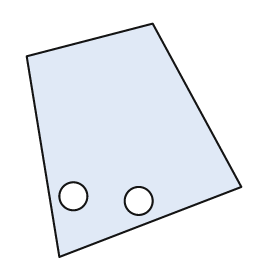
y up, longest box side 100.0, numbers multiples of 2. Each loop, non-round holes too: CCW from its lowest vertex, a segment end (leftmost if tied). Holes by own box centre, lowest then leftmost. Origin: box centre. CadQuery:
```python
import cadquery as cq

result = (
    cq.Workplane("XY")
    .moveTo(-32.0, -50.0)
    .lineTo(46.0, -20.0)
    .lineTo(8.0, 50.0)
    .lineTo(-46.0, 36.0)
    .close()
    .moveTo(2.0, -26.0)
    .circle(6.0)
    .moveTo(-26.0, -24.0)
    .circle(6.0)
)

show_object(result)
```